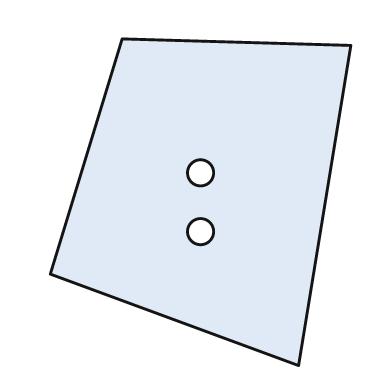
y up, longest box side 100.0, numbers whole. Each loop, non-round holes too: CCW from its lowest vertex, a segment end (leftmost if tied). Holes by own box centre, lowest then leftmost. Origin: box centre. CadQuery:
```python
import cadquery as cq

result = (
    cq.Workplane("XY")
    .moveTo(30.0, -50.0)
    .lineTo(46.0, 48.0)
    .lineTo(-24.0, 50.0)
    .lineTo(-46.0, -22.0)
    .close()
    .moveTo(0.0, -9.0)
    .circle(4.0)
    .moveTo(0.0, 9.0)
    .circle(4.0)
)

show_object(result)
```